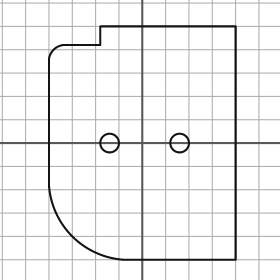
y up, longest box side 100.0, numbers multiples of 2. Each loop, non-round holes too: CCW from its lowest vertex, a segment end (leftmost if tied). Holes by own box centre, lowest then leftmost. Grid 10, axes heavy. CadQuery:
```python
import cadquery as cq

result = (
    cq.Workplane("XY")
    .moveTo(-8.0, -50.0)
    .lineTo(40.0, -50.0)
    .lineTo(40.0, 50.0)
    .lineTo(-18.0, 50.0)
    .lineTo(-18.0, 42.0)
    .lineTo(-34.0, 42.0)
    .threePointArc((-38.0, 40.0), (-40.0, 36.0))
    .lineTo(-40.0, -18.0)
    .threePointArc((-30.0, -40.0), (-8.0, -50.0))
    .close()
    .moveTo(-14.0, 0.0)
    .circle(4.0)
    .moveTo(16.0, 0.0)
    .circle(4.0)
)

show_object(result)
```